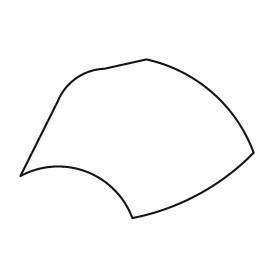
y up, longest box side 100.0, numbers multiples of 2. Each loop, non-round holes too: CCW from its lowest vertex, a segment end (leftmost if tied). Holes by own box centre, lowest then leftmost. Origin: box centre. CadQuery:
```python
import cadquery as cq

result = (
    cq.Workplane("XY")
    .moveTo(-2.0, -34.0)
    .threePointArc((26.0, -24.0), (50.0, -6.0))
    .threePointArc((32.0, 20.0), (4.0, 34.0))
    .lineTo(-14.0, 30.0)
    .threePointArc((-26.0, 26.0), (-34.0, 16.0))
    .lineTo(-50.0, -16.0)
    .threePointArc((-22.0, -14.0), (-2.0, -34.0))
    .close()
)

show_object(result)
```